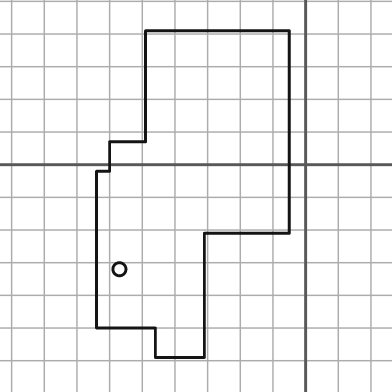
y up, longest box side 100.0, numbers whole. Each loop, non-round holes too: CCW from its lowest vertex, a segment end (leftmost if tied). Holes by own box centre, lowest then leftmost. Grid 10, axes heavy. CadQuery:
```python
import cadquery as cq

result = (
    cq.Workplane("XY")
    .moveTo(-46.0, -59.0)
    .lineTo(-31.0, -59.0)
    .lineTo(-31.0, -21.0)
    .lineTo(-5.0, -21.0)
    .lineTo(-5.0, 41.0)
    .lineTo(-49.0, 41.0)
    .lineTo(-49.0, 7.0)
    .lineTo(-60.0, 7.0)
    .lineTo(-60.0, -2.0)
    .lineTo(-64.0, -2.0)
    .lineTo(-64.0, -50.0)
    .lineTo(-46.0, -50.0)
    .close()
    .moveTo(-57.0, -32.0)
    .circle(2.0)
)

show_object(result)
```